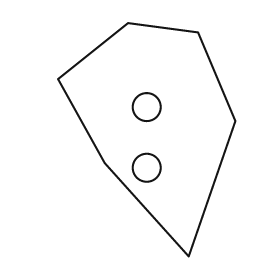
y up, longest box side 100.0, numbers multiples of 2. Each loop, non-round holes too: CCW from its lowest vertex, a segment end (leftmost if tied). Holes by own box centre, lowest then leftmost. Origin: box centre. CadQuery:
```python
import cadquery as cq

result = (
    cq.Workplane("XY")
    .moveTo(18.0, -50.0)
    .lineTo(38.0, 8.0)
    .lineTo(22.0, 46.0)
    .lineTo(-8.0, 50.0)
    .lineTo(-38.0, 26.0)
    .lineTo(-18.0, -10.0)
    .close()
    .moveTo(0.0, -12.0)
    .circle(6.0)
    .moveTo(0.0, 14.0)
    .circle(6.0)
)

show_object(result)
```